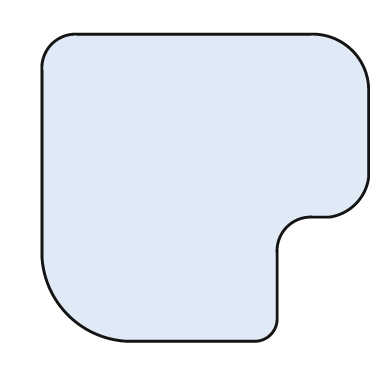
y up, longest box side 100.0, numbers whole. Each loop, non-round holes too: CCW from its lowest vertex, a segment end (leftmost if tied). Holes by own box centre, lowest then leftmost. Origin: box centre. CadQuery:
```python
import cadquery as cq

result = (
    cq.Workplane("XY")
    .moveTo(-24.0, -47.0)
    .lineTo(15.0, -47.0)
    .threePointArc((20.0, -45.0), (22.0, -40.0))
    .lineTo(22.0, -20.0)
    .threePointArc((25.0, -12.0), (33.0, -9.0))
    .lineTo(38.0, -9.0)
    .threePointArc((46.0, -5.0), (50.0, 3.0))
    .lineTo(50.0, 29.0)
    .threePointArc((45.0, 42.0), (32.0, 47.0))
    .lineTo(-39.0, 47.0)
    .threePointArc((-47.0, 44.0), (-50.0, 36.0))
    .lineTo(-50.0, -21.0)
    .threePointArc((-42.0, -39.0), (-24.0, -47.0))
    .close()
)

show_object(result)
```